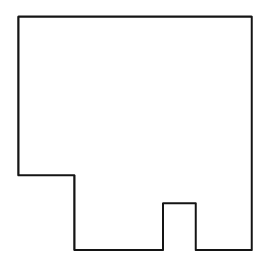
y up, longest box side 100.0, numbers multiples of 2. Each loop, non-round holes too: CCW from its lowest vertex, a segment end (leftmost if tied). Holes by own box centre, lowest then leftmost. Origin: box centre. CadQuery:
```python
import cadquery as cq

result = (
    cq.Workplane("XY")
    .moveTo(-26.0, -50.0)
    .lineTo(12.0, -50.0)
    .lineTo(12.0, -30.0)
    .lineTo(26.0, -30.0)
    .lineTo(26.0, -50.0)
    .lineTo(50.0, -50.0)
    .lineTo(50.0, 50.0)
    .lineTo(-50.0, 50.0)
    .lineTo(-50.0, -18.0)
    .lineTo(-26.0, -18.0)
    .close()
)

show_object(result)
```